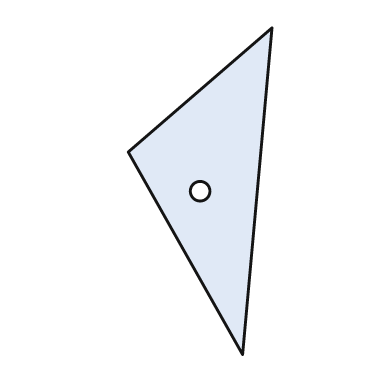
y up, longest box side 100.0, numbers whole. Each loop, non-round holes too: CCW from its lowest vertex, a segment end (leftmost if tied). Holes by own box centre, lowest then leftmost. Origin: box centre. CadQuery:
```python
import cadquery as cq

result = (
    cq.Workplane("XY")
    .moveTo(13.0, -50.0)
    .lineTo(22.0, 50.0)
    .lineTo(-22.0, 12.0)
    .close()
    .moveTo(0.0, 0.0)
    .circle(3.0)
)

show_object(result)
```